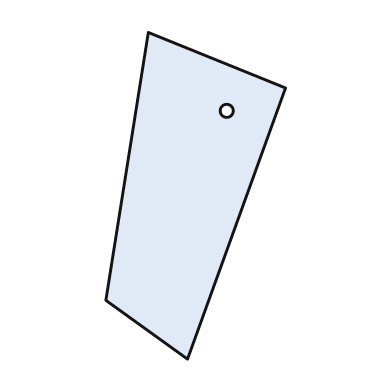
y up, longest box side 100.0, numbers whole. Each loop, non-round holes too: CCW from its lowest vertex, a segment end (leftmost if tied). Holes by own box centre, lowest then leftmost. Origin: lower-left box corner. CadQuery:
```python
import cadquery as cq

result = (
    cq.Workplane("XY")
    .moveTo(25.0, 0.0)
    .lineTo(55.0, 83.0)
    .lineTo(13.0, 100.0)
    .lineTo(0.0, 18.0)
    .close()
    .moveTo(37.0, 76.0)
    .circle(2.0)
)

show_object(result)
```